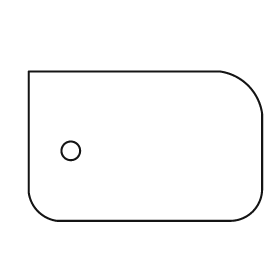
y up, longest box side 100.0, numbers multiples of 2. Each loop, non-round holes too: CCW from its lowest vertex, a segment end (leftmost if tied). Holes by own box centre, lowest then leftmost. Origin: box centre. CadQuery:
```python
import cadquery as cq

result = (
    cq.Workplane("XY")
    .moveTo(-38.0, -32.0)
    .lineTo(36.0, -32.0)
    .threePointArc((46.0, -28.0), (50.0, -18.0))
    .lineTo(50.0, 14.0)
    .threePointArc((44.0, 26.0), (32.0, 32.0))
    .lineTo(-50.0, 32.0)
    .lineTo(-50.0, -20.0)
    .threePointArc((-46.0, -28.0), (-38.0, -32.0))
    .close()
    .moveTo(-32.0, -2.0)
    .circle(4.0)
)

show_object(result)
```